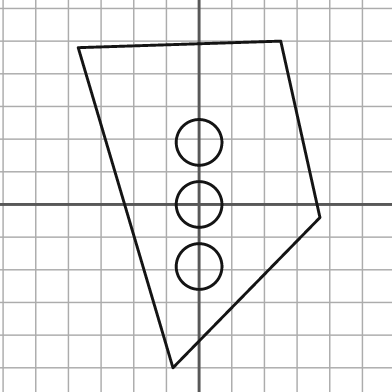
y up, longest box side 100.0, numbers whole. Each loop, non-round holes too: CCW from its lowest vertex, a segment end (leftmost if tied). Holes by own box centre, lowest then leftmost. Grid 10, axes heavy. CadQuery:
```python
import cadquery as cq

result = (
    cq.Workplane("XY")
    .moveTo(-8.0, -50.0)
    .lineTo(37.0, -4.0)
    .lineTo(25.0, 50.0)
    .lineTo(-37.0, 48.0)
    .close()
    .moveTo(0.0, -19.0)
    .circle(7.0)
    .moveTo(0.0, 0.0)
    .circle(7.0)
    .moveTo(0.0, 19.0)
    .circle(7.0)
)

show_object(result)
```